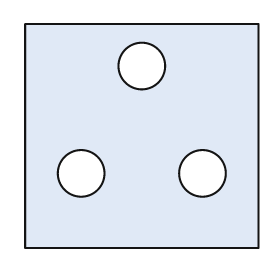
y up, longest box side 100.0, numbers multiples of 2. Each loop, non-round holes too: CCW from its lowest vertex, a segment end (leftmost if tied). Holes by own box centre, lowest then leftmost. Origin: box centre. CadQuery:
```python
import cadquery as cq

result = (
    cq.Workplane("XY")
    .moveTo(-50.0, -48.0)
    .lineTo(50.0, -48.0)
    .lineTo(50.0, 48.0)
    .lineTo(-50.0, 48.0)
    .close()
    .moveTo(-26.0, -16.0)
    .circle(10.0)
    .moveTo(26.0, -16.0)
    .circle(10.0)
    .moveTo(0.0, 30.0)
    .circle(10.0)
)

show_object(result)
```